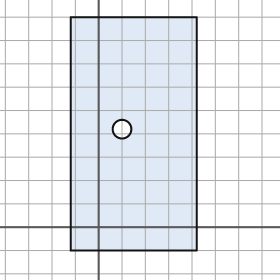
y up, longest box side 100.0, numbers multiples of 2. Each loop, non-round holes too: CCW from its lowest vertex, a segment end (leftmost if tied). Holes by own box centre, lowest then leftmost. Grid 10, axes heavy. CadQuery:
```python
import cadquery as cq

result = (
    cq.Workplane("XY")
    .moveTo(-12.0, -10.0)
    .lineTo(42.0, -10.0)
    .lineTo(42.0, 90.0)
    .lineTo(-12.0, 90.0)
    .close()
    .moveTo(10.0, 42.0)
    .circle(4.0)
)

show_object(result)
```